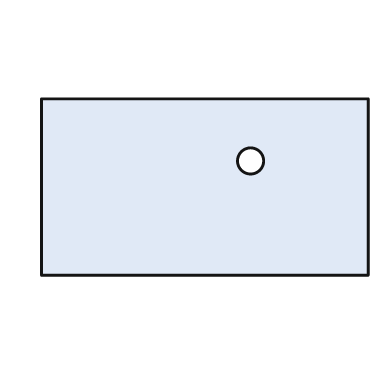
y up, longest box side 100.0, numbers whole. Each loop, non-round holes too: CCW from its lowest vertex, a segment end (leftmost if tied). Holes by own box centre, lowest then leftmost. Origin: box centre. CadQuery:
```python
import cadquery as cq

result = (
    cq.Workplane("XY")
    .moveTo(-50.0, -27.0)
    .lineTo(50.0, -27.0)
    .lineTo(50.0, 27.0)
    .lineTo(-50.0, 27.0)
    .close()
    .moveTo(14.0, 8.0)
    .circle(4.0)
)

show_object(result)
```